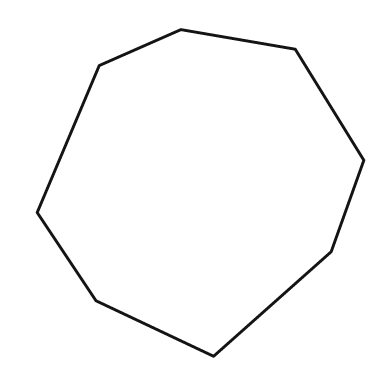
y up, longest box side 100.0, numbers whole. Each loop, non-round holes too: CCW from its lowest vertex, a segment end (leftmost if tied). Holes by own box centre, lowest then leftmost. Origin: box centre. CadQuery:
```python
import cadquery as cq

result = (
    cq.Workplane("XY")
    .moveTo(4.0, -50.0)
    .lineTo(40.0, -18.0)
    .lineTo(50.0, 10.0)
    .lineTo(29.0, 44.0)
    .lineTo(-6.0, 50.0)
    .lineTo(-31.0, 39.0)
    .lineTo(-50.0, -6.0)
    .lineTo(-32.0, -33.0)
    .close()
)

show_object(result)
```